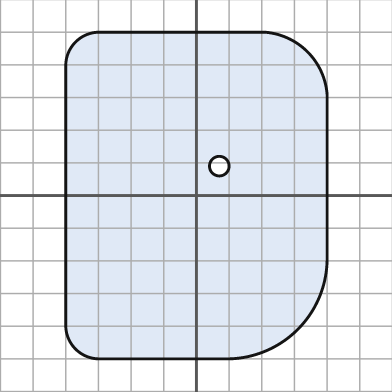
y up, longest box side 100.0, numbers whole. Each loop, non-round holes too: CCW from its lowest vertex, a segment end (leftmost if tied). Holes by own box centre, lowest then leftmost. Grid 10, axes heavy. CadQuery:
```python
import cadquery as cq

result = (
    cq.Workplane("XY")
    .moveTo(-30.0, -50.0)
    .lineTo(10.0, -50.0)
    .threePointArc((31.0, -41.0), (40.0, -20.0))
    .lineTo(40.0, 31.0)
    .threePointArc((34.0, 44.0), (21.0, 50.0))
    .lineTo(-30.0, 50.0)
    .threePointArc((-37.0, 47.0), (-40.0, 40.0))
    .lineTo(-40.0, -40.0)
    .threePointArc((-37.0, -47.0), (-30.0, -50.0))
    .close()
    .moveTo(7.0, 9.0)
    .circle(3.0)
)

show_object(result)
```